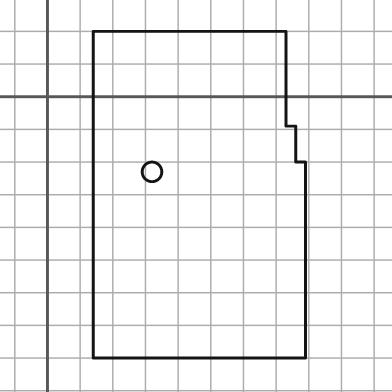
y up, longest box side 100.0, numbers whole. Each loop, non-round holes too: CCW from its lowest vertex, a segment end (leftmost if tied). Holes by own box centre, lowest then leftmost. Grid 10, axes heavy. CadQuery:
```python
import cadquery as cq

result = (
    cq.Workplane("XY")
    .moveTo(14.0, -80.0)
    .lineTo(79.0, -80.0)
    .lineTo(79.0, -20.0)
    .lineTo(76.0, -20.0)
    .lineTo(76.0, -9.0)
    .lineTo(73.0, -9.0)
    .lineTo(73.0, 20.0)
    .lineTo(14.0, 20.0)
    .close()
    .moveTo(32.0, -23.0)
    .circle(3.0)
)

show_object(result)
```